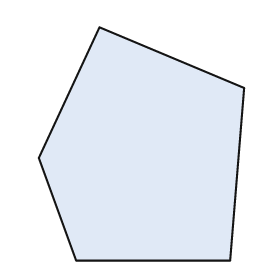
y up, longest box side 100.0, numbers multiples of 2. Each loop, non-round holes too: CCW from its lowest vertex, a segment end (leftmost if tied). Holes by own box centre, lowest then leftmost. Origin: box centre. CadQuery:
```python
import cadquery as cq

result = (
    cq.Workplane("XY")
    .moveTo(-28.0, -50.0)
    .lineTo(38.0, -50.0)
    .lineTo(44.0, 24.0)
    .lineTo(-18.0, 50.0)
    .lineTo(-44.0, -6.0)
    .close()
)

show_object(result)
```